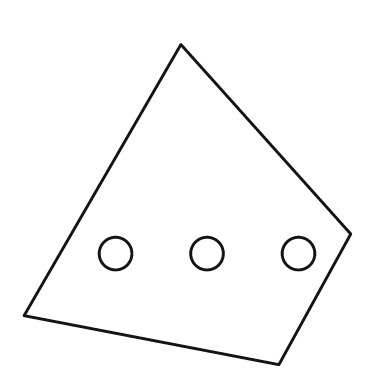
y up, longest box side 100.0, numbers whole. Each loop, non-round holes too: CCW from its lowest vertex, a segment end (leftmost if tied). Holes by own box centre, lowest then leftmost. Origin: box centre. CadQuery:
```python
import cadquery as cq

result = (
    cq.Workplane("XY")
    .moveTo(28.0, -49.0)
    .lineTo(50.0, -9.0)
    .lineTo(-2.0, 49.0)
    .lineTo(-50.0, -34.0)
    .close()
    .moveTo(-22.0, -15.0)
    .circle(5.0)
    .moveTo(6.0, -15.0)
    .circle(5.0)
    .moveTo(34.0, -15.0)
    .circle(5.0)
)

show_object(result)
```